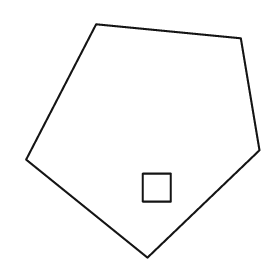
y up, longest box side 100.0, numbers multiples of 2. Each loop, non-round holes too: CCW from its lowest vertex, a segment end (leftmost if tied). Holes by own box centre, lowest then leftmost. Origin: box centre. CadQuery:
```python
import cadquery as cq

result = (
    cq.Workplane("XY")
    .moveTo(2.0, -50.0)
    .lineTo(50.0, -4.0)
    .lineTo(42.0, 44.0)
    .lineTo(-20.0, 50.0)
    .lineTo(-50.0, -8.0)
    .close()
    .moveTo(0.0, -26.0)
    .lineTo(12.0, -26.0)
    .lineTo(12.0, -14.0)
    .lineTo(0.0, -14.0)
    .close()
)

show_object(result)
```